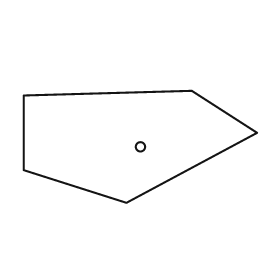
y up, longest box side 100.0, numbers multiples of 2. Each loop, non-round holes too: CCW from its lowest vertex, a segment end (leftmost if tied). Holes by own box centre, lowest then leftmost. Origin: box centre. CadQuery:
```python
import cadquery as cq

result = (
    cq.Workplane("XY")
    .moveTo(-6.0, -24.0)
    .lineTo(50.0, 6.0)
    .lineTo(22.0, 24.0)
    .lineTo(-50.0, 22.0)
    .lineTo(-50.0, -10.0)
    .close()
    .moveTo(0.0, 0.0)
    .circle(2.0)
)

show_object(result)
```